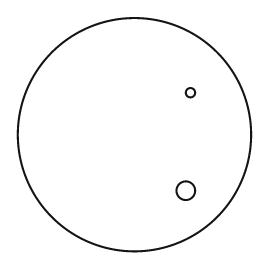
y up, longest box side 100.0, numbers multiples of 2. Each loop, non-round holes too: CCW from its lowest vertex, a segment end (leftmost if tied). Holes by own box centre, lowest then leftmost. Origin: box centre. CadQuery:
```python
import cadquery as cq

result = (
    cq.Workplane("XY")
    .moveTo(0.0, 0.0)
    .circle(50.0)
    .moveTo(22.0, -24.0)
    .circle(4.0)
    .moveTo(24.0, 18.0)
    .circle(2.0)
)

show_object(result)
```